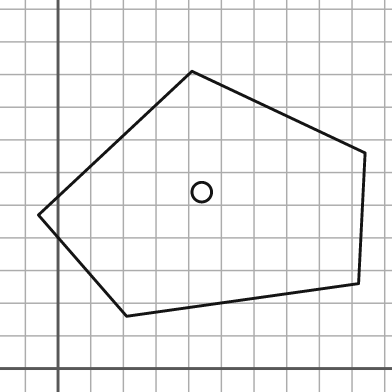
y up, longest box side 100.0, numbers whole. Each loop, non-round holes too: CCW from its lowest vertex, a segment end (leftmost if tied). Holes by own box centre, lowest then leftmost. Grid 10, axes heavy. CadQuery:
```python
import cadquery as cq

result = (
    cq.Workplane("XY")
    .moveTo(21.0, 16.0)
    .lineTo(92.0, 26.0)
    .lineTo(94.0, 66.0)
    .lineTo(41.0, 91.0)
    .lineTo(-6.0, 47.0)
    .close()
    .moveTo(44.0, 54.0)
    .circle(3.0)
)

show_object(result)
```